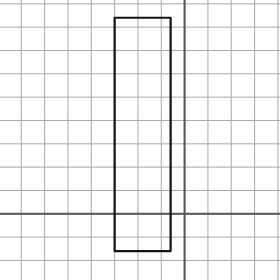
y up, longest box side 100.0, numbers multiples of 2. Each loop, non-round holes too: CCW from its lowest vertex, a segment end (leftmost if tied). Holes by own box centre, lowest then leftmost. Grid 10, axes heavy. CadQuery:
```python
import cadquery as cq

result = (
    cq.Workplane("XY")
    .moveTo(-30.0, -16.0)
    .lineTo(-6.0, -16.0)
    .lineTo(-6.0, 84.0)
    .lineTo(-30.0, 84.0)
    .close()
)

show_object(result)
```